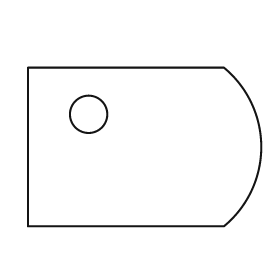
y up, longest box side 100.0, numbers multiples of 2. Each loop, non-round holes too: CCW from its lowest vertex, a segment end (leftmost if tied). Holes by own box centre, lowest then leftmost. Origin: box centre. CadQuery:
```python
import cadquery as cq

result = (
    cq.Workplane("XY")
    .moveTo(-50.0, -34.0)
    .lineTo(34.0, -34.0)
    .threePointArc((50.0, 0.0), (34.0, 34.0))
    .lineTo(-50.0, 34.0)
    .close()
    .moveTo(-24.0, 14.0)
    .circle(8.0)
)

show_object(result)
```